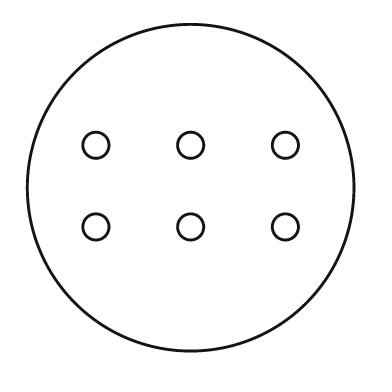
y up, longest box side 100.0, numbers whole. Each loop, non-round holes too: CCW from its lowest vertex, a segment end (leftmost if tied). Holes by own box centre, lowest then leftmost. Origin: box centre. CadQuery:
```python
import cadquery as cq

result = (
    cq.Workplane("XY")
    .moveTo(0.0, 0.0)
    .circle(50.0)
    .moveTo(-29.0, -12.0)
    .circle(4.0)
    .moveTo(0.0, -12.0)
    .circle(4.0)
    .moveTo(29.0, -12.0)
    .circle(4.0)
    .moveTo(-29.0, 13.0)
    .circle(4.0)
    .moveTo(0.0, 13.0)
    .circle(4.0)
    .moveTo(29.0, 13.0)
    .circle(4.0)
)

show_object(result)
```